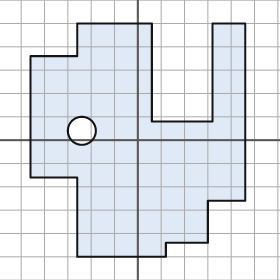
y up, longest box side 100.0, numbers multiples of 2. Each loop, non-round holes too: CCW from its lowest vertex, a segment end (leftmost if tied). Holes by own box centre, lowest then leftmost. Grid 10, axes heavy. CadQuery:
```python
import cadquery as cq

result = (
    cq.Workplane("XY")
    .moveTo(-26.0, -50.0)
    .lineTo(12.0, -50.0)
    .lineTo(12.0, -44.0)
    .lineTo(30.0, -44.0)
    .lineTo(30.0, -26.0)
    .lineTo(46.0, -26.0)
    .lineTo(46.0, 50.0)
    .lineTo(32.0, 50.0)
    .lineTo(32.0, 8.0)
    .lineTo(6.0, 8.0)
    .lineTo(6.0, 50.0)
    .lineTo(-26.0, 50.0)
    .lineTo(-26.0, 36.0)
    .lineTo(-46.0, 36.0)
    .lineTo(-46.0, -16.0)
    .lineTo(-26.0, -16.0)
    .close()
    .moveTo(-24.0, 4.0)
    .circle(6.0)
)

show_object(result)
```